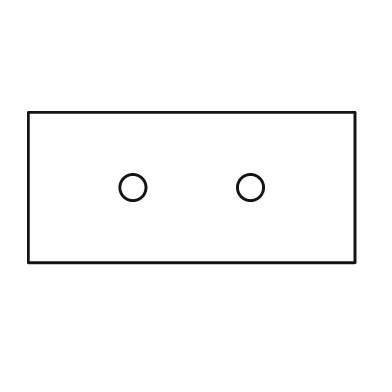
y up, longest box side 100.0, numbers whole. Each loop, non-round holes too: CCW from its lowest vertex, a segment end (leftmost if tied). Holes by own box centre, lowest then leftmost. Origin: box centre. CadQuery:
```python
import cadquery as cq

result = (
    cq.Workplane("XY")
    .moveTo(-50.0, -23.0)
    .lineTo(50.0, -23.0)
    .lineTo(50.0, 23.0)
    .lineTo(-50.0, 23.0)
    .close()
    .moveTo(-18.0, 0.0)
    .circle(4.0)
    .moveTo(18.0, 0.0)
    .circle(4.0)
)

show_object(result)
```